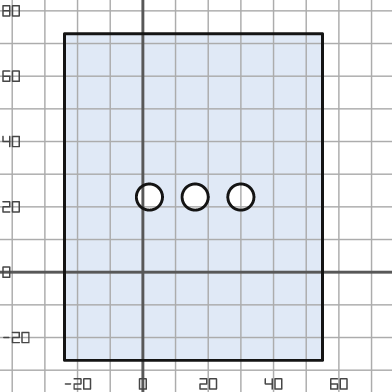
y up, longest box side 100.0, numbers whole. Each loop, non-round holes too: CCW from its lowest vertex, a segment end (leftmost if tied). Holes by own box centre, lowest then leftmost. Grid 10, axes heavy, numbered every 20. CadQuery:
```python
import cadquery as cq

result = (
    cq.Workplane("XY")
    .moveTo(-24.0, -27.0)
    .lineTo(55.0, -27.0)
    .lineTo(55.0, 73.0)
    .lineTo(-24.0, 73.0)
    .close()
    .moveTo(2.0, 23.0)
    .circle(4.0)
    .moveTo(16.0, 23.0)
    .circle(4.0)
    .moveTo(30.0, 23.0)
    .circle(4.0)
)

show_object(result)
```